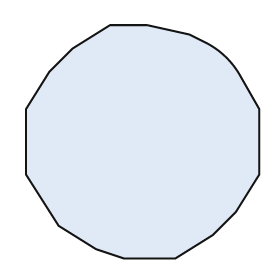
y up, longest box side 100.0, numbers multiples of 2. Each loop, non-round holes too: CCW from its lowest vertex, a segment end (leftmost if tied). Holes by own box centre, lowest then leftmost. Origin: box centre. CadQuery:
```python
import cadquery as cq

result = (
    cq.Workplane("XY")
    .moveTo(-8.0, -50.0)
    .lineTo(14.0, -50.0)
    .lineTo(30.0, -40.0)
    .lineTo(40.0, -30.0)
    .lineTo(50.0, -14.0)
    .lineTo(50.0, 14.0)
    .lineTo(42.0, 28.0)
    .threePointArc((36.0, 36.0), (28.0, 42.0))
    .lineTo(20.0, 46.0)
    .lineTo(2.0, 50.0)
    .lineTo(-14.0, 50.0)
    .lineTo(-30.0, 40.0)
    .lineTo(-40.0, 30.0)
    .lineTo(-50.0, 14.0)
    .lineTo(-50.0, -14.0)
    .lineTo(-36.0, -36.0)
    .lineTo(-20.0, -46.0)
    .close()
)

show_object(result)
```